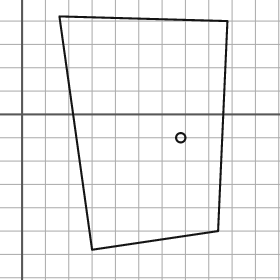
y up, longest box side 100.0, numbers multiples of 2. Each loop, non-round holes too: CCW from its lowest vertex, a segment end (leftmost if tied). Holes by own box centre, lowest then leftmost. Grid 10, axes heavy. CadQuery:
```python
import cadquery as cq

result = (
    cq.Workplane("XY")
    .moveTo(30.0, -58.0)
    .lineTo(84.0, -50.0)
    .lineTo(88.0, 40.0)
    .lineTo(16.0, 42.0)
    .close()
    .moveTo(68.0, -10.0)
    .circle(2.0)
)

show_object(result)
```